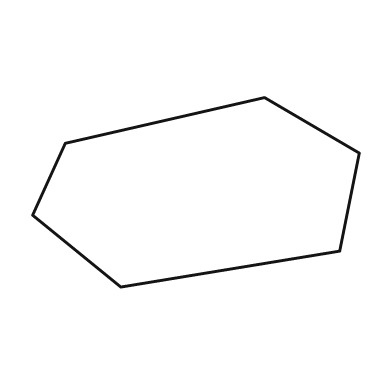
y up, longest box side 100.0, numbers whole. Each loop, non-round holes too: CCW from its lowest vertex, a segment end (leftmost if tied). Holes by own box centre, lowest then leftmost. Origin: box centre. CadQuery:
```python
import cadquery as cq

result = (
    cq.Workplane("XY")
    .moveTo(-23.0, -29.0)
    .lineTo(44.0, -18.0)
    .lineTo(50.0, 12.0)
    .lineTo(21.0, 29.0)
    .lineTo(-40.0, 15.0)
    .lineTo(-50.0, -7.0)
    .close()
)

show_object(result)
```